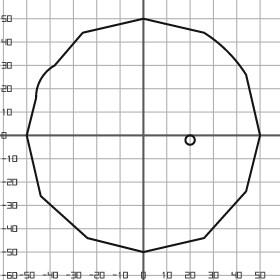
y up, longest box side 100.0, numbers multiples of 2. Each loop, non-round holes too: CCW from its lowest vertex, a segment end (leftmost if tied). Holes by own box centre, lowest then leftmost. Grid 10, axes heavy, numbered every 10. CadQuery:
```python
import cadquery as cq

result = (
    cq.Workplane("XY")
    .moveTo(0.0, -50.0)
    .lineTo(26.0, -44.0)
    .lineTo(44.0, -24.0)
    .lineTo(50.0, 0.0)
    .lineTo(44.0, 26.0)
    .threePointArc((36.0, 36.0), (26.0, 44.0))
    .lineTo(0.0, 50.0)
    .lineTo(-26.0, 44.0)
    .lineTo(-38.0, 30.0)
    .threePointArc((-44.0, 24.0), (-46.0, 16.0))
    .lineTo(-50.0, 0.0)
    .lineTo(-44.0, -26.0)
    .lineTo(-24.0, -44.0)
    .close()
    .moveTo(20.0, -2.0)
    .circle(2.0)
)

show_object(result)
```